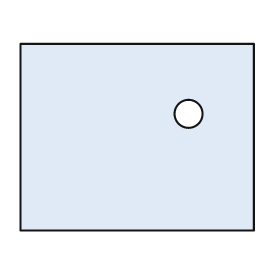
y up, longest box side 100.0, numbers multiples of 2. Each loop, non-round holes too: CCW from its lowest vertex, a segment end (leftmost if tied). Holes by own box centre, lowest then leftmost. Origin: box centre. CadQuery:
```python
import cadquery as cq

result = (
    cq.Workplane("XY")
    .moveTo(-50.0, -40.0)
    .lineTo(50.0, -40.0)
    .lineTo(50.0, 40.0)
    .lineTo(-50.0, 40.0)
    .close()
    .moveTo(22.0, 10.0)
    .circle(6.0)
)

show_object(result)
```